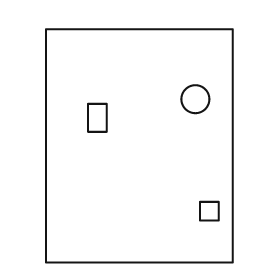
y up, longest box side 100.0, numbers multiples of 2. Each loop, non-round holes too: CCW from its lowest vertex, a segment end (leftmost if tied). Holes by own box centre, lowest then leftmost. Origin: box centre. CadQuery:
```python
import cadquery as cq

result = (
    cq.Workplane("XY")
    .moveTo(-40.0, -50.0)
    .lineTo(40.0, -50.0)
    .lineTo(40.0, 50.0)
    .lineTo(-40.0, 50.0)
    .close()
    .moveTo(26.0, -32.0)
    .lineTo(34.0, -32.0)
    .lineTo(34.0, -24.0)
    .lineTo(26.0, -24.0)
    .close()
    .moveTo(-22.0, 6.0)
    .lineTo(-14.0, 6.0)
    .lineTo(-14.0, 18.0)
    .lineTo(-22.0, 18.0)
    .close()
    .moveTo(24.0, 20.0)
    .circle(6.0)
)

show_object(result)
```